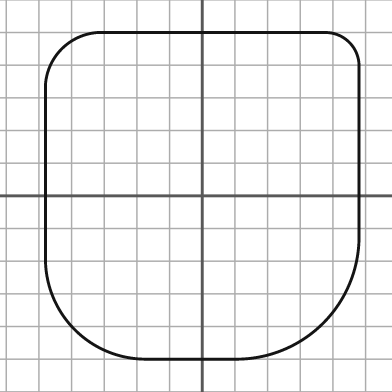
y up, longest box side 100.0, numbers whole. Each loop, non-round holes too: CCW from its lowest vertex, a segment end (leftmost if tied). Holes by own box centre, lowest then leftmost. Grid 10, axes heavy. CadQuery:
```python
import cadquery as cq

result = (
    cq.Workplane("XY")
    .moveTo(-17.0, -50.0)
    .lineTo(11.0, -50.0)
    .threePointArc((37.0, -39.0), (48.0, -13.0))
    .lineTo(48.0, 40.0)
    .threePointArc((45.0, 47.0), (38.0, 50.0))
    .lineTo(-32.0, 50.0)
    .threePointArc((-43.0, 45.0), (-48.0, 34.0))
    .lineTo(-48.0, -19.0)
    .threePointArc((-39.0, -41.0), (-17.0, -50.0))
    .close()
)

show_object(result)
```